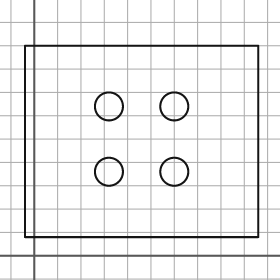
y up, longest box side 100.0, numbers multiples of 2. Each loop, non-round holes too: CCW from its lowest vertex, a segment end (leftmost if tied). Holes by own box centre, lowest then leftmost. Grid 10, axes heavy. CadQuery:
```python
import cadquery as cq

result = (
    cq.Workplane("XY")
    .moveTo(-4.0, 8.0)
    .lineTo(96.0, 8.0)
    .lineTo(96.0, 90.0)
    .lineTo(-4.0, 90.0)
    .close()
    .moveTo(32.0, 36.0)
    .circle(6.0)
    .moveTo(60.0, 36.0)
    .circle(6.0)
    .moveTo(32.0, 64.0)
    .circle(6.0)
    .moveTo(60.0, 64.0)
    .circle(6.0)
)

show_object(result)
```